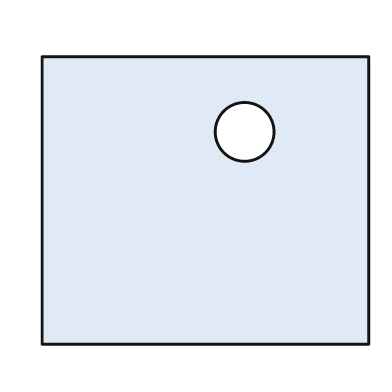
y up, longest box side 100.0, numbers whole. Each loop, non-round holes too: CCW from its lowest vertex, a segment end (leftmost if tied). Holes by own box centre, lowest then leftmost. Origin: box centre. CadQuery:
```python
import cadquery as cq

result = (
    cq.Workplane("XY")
    .moveTo(-50.0, -44.0)
    .lineTo(50.0, -44.0)
    .lineTo(50.0, 44.0)
    .lineTo(-50.0, 44.0)
    .close()
    .moveTo(12.0, 21.0)
    .circle(9.0)
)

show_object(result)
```